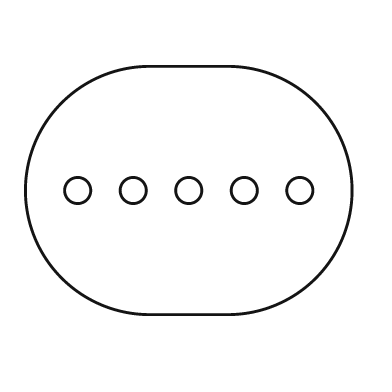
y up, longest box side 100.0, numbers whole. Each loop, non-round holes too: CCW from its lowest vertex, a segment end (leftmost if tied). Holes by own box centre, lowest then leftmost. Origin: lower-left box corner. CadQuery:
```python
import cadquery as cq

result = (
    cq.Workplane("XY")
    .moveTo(38.0, 0.0)
    .lineTo(62.0, 0.0)
    .threePointArc((100.0, 38.0), (62.0, 76.0))
    .lineTo(38.0, 76.0)
    .threePointArc((0.0, 38.0), (38.0, 0.0))
    .close()
    .moveTo(16.0, 38.0)
    .circle(4.0)
    .moveTo(33.0, 38.0)
    .circle(4.0)
    .moveTo(50.0, 38.0)
    .circle(4.0)
    .moveTo(67.0, 38.0)
    .circle(4.0)
    .moveTo(84.0, 38.0)
    .circle(4.0)
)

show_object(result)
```